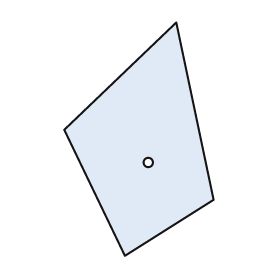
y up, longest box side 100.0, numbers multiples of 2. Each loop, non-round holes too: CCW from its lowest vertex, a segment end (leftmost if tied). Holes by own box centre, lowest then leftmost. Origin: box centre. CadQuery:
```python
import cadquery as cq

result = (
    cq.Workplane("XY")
    .moveTo(-6.0, -50.0)
    .lineTo(32.0, -26.0)
    .lineTo(16.0, 50.0)
    .lineTo(-32.0, 4.0)
    .close()
    .moveTo(4.0, -10.0)
    .circle(2.0)
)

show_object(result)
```